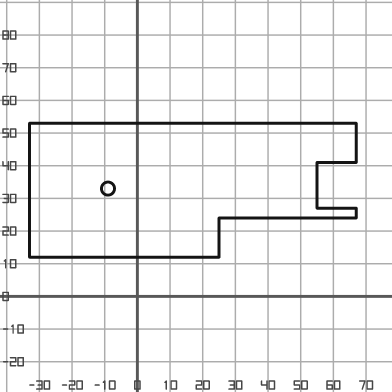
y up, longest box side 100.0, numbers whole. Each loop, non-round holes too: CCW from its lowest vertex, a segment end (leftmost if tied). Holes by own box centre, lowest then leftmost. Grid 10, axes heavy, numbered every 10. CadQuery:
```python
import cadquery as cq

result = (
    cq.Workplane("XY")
    .moveTo(-33.0, 12.0)
    .lineTo(25.0, 12.0)
    .lineTo(25.0, 24.0)
    .lineTo(67.0, 24.0)
    .lineTo(67.0, 27.0)
    .lineTo(55.0, 27.0)
    .lineTo(55.0, 41.0)
    .lineTo(67.0, 41.0)
    .lineTo(67.0, 53.0)
    .lineTo(-33.0, 53.0)
    .close()
    .moveTo(-9.0, 33.0)
    .circle(2.0)
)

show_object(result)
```